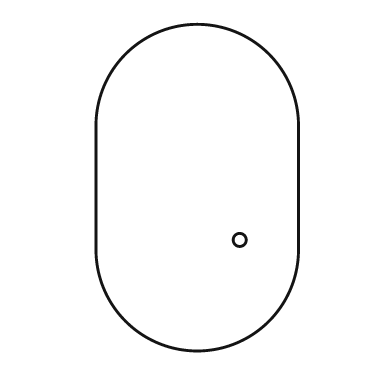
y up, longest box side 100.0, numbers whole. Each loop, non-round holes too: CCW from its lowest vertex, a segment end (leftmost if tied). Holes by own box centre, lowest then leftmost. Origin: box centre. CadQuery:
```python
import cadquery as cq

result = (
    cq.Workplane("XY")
    .moveTo(-31.0, -19.0)
    .threePointArc((0.0, -50.0), (31.0, -19.0))
    .lineTo(31.0, 19.0)
    .threePointArc((0.0, 50.0), (-31.0, 19.0))
    .close()
    .moveTo(13.0, -16.0)
    .circle(2.0)
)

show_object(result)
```